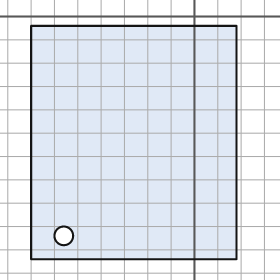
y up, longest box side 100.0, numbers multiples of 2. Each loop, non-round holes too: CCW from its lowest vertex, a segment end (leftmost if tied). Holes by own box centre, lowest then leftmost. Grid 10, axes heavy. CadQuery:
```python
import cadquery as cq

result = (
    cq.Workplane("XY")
    .moveTo(-70.0, -104.0)
    .lineTo(18.0, -104.0)
    .lineTo(18.0, -4.0)
    .lineTo(-70.0, -4.0)
    .close()
    .moveTo(-56.0, -94.0)
    .circle(4.0)
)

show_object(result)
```